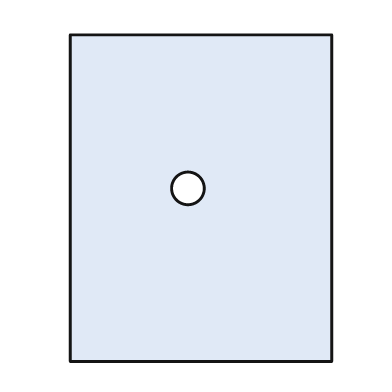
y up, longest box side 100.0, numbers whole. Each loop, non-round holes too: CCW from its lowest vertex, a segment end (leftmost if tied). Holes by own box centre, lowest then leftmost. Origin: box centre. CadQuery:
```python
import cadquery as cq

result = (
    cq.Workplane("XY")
    .moveTo(-40.0, -50.0)
    .lineTo(40.0, -50.0)
    .lineTo(40.0, 50.0)
    .lineTo(-40.0, 50.0)
    .close()
    .moveTo(-4.0, 3.0)
    .circle(5.0)
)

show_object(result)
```